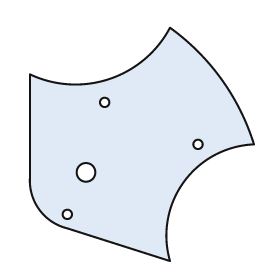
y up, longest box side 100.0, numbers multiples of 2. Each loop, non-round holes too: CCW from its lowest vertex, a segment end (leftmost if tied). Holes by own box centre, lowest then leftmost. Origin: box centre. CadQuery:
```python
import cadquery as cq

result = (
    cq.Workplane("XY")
    .moveTo(12.0, -50.0)
    .threePointArc((18.0, -16.0), (48.0, 0.0))
    .threePointArc((34.0, 28.0), (12.0, 50.0))
    .threePointArc((-14.0, 28.0), (-48.0, 30.0))
    .lineTo(-48.0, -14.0)
    .threePointArc((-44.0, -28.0), (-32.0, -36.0))
    .close()
    .moveTo(-32.0, -30.0)
    .circle(2.0)
    .moveTo(-24.0, -12.0)
    .circle(4.0)
    .moveTo(24.0, 0.0)
    .circle(2.0)
    .moveTo(-16.0, 18.0)
    .circle(2.0)
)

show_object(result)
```